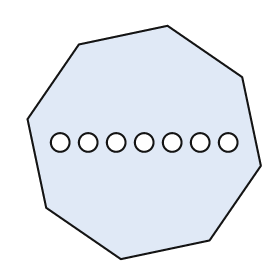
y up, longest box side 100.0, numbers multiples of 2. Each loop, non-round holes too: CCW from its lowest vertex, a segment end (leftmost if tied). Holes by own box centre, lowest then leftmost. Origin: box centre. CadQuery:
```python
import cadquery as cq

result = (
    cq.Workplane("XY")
    .moveTo(-10.0, -50.0)
    .lineTo(28.0, -42.0)
    .lineTo(50.0, -10.0)
    .lineTo(42.0, 28.0)
    .lineTo(10.0, 50.0)
    .lineTo(-28.0, 42.0)
    .lineTo(-50.0, 10.0)
    .lineTo(-42.0, -28.0)
    .close()
    .moveTo(-36.0, 0.0)
    .circle(4.0)
    .moveTo(-24.0, 0.0)
    .circle(4.0)
    .moveTo(-12.0, 0.0)
    .circle(4.0)
    .moveTo(0.0, 0.0)
    .circle(4.0)
    .moveTo(12.0, 0.0)
    .circle(4.0)
    .moveTo(24.0, 0.0)
    .circle(4.0)
    .moveTo(36.0, 0.0)
    .circle(4.0)
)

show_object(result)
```